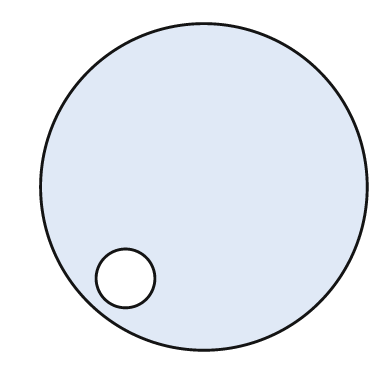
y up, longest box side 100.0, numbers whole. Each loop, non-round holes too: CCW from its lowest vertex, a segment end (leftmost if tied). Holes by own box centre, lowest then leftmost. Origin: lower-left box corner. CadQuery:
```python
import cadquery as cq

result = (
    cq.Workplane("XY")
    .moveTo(50.0, 50.0)
    .circle(50.0)
    .moveTo(26.0, 22.0)
    .circle(9.0)
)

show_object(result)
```